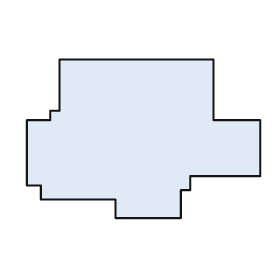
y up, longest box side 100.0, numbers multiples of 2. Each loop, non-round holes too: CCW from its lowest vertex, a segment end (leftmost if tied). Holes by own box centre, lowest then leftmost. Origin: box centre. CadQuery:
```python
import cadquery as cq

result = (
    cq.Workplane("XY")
    .moveTo(-12.0, -34.0)
    .lineTo(16.0, -34.0)
    .lineTo(16.0, -22.0)
    .lineTo(20.0, -22.0)
    .lineTo(20.0, -16.0)
    .lineTo(50.0, -16.0)
    .lineTo(50.0, 8.0)
    .lineTo(30.0, 8.0)
    .lineTo(30.0, 34.0)
    .lineTo(-36.0, 34.0)
    .lineTo(-36.0, 12.0)
    .lineTo(-40.0, 12.0)
    .lineTo(-40.0, 8.0)
    .lineTo(-50.0, 8.0)
    .lineTo(-50.0, -20.0)
    .lineTo(-44.0, -20.0)
    .lineTo(-44.0, -26.0)
    .lineTo(-12.0, -26.0)
    .close()
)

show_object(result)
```